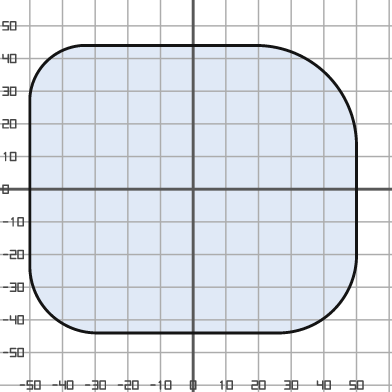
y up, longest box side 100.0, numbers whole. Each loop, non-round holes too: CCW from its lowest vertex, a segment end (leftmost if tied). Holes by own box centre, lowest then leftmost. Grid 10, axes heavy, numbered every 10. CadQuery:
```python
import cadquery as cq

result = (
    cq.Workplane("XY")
    .moveTo(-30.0, -44.0)
    .lineTo(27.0, -44.0)
    .threePointArc((43.0, -37.0), (50.0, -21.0))
    .lineTo(50.0, 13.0)
    .threePointArc((41.0, 35.0), (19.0, 44.0))
    .lineTo(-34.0, 44.0)
    .threePointArc((-45.0, 39.0), (-50.0, 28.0))
    .lineTo(-50.0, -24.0)
    .threePointArc((-44.0, -38.0), (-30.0, -44.0))
    .close()
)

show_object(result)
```